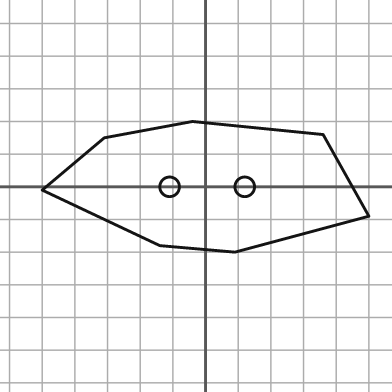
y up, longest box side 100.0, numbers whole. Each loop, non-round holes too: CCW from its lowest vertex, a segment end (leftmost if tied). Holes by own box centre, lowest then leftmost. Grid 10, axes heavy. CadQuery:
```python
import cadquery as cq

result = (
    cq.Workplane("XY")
    .moveTo(9.0, -20.0)
    .lineTo(50.0, -9.0)
    .lineTo(36.0, 16.0)
    .lineTo(-4.0, 20.0)
    .lineTo(-31.0, 15.0)
    .lineTo(-50.0, -1.0)
    .lineTo(-14.0, -18.0)
    .close()
    .moveTo(-11.0, 0.0)
    .circle(3.0)
    .moveTo(12.0, 0.0)
    .circle(3.0)
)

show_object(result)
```